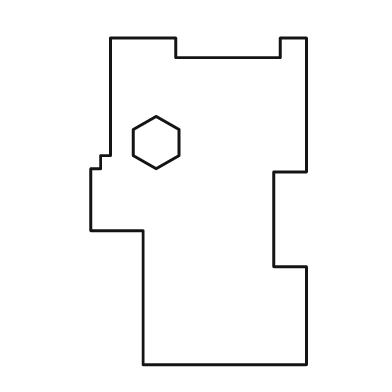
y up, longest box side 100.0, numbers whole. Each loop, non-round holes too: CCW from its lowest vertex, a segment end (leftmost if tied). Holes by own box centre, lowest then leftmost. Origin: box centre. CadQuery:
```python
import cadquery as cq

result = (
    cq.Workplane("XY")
    .moveTo(-17.0, -50.0)
    .lineTo(33.0, -50.0)
    .lineTo(33.0, -20.0)
    .lineTo(23.0, -20.0)
    .lineTo(23.0, 9.0)
    .lineTo(33.0, 9.0)
    .lineTo(33.0, 50.0)
    .lineTo(25.0, 50.0)
    .lineTo(25.0, 44.0)
    .lineTo(-7.0, 44.0)
    .lineTo(-7.0, 50.0)
    .lineTo(-27.0, 50.0)
    .lineTo(-27.0, 14.0)
    .lineTo(-30.0, 14.0)
    .lineTo(-30.0, 10.0)
    .lineTo(-33.0, 10.0)
    .lineTo(-33.0, -9.0)
    .lineTo(-17.0, -9.0)
    .close()
    .moveTo(-13.0, 10.0)
    .lineTo(-6.0, 14.0)
    .lineTo(-6.0, 22.0)
    .lineTo(-13.0, 26.0)
    .lineTo(-20.0, 22.0)
    .lineTo(-20.0, 14.0)
    .close()
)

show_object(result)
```